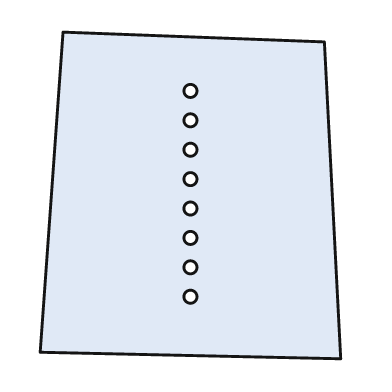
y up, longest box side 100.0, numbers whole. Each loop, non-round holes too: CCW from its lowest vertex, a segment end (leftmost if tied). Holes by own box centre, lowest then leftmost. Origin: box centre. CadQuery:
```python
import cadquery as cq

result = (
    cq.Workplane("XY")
    .moveTo(46.0, -50.0)
    .lineTo(41.0, 47.0)
    .lineTo(-39.0, 50.0)
    .lineTo(-46.0, -48.0)
    .close()
    .moveTo(0.0, -31.0)
    .circle(2.0)
    .moveTo(0.0, -22.0)
    .circle(2.0)
    .moveTo(0.0, -13.0)
    .circle(2.0)
    .moveTo(0.0, -4.0)
    .circle(2.0)
    .moveTo(0.0, 5.0)
    .circle(2.0)
    .moveTo(0.0, 14.0)
    .circle(2.0)
    .moveTo(0.0, 23.0)
    .circle(2.0)
    .moveTo(0.0, 32.0)
    .circle(2.0)
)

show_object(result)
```